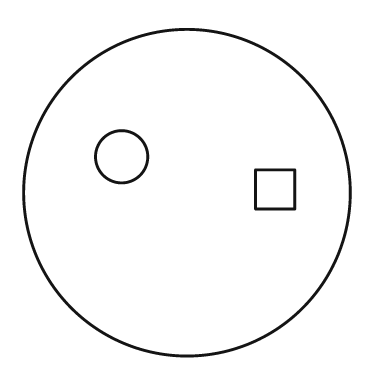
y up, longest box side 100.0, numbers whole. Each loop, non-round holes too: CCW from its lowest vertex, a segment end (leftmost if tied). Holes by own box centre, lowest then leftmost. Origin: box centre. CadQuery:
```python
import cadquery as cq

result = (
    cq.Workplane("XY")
    .moveTo(0.0, 0.0)
    .circle(50.0)
    .moveTo(21.0, -5.0)
    .lineTo(33.0, -5.0)
    .lineTo(33.0, 7.0)
    .lineTo(21.0, 7.0)
    .close()
    .moveTo(-20.0, 11.0)
    .circle(8.0)
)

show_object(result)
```